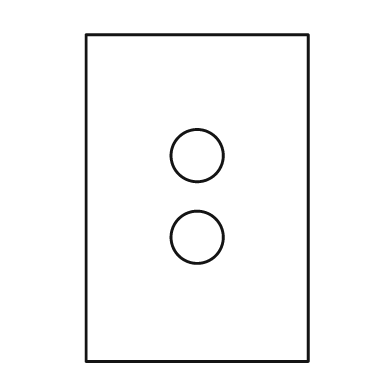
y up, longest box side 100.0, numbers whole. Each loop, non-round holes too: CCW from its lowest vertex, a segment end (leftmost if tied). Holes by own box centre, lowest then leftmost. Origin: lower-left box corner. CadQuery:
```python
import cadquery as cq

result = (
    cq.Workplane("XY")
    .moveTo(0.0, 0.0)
    .lineTo(68.0, 0.0)
    .lineTo(68.0, 100.0)
    .lineTo(0.0, 100.0)
    .close()
    .moveTo(34.0, 38.0)
    .circle(8.0)
    .moveTo(34.0, 63.0)
    .circle(8.0)
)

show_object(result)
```